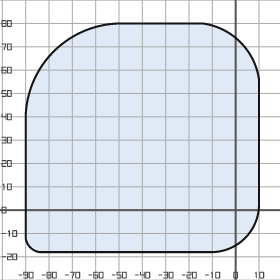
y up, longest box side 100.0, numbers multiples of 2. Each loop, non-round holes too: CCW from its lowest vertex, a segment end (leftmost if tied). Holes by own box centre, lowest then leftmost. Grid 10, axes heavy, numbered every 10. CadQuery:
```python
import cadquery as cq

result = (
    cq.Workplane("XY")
    .moveTo(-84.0, -18.0)
    .lineTo(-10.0, -18.0)
    .threePointArc((4.0, -12.0), (10.0, 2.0))
    .lineTo(10.0, 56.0)
    .threePointArc((2.0, 72.0), (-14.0, 80.0))
    .lineTo(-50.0, 80.0)
    .threePointArc((-78.0, 68.0), (-90.0, 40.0))
    .lineTo(-90.0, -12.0)
    .threePointArc((-88.0, -16.0), (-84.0, -18.0))
    .close()
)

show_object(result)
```